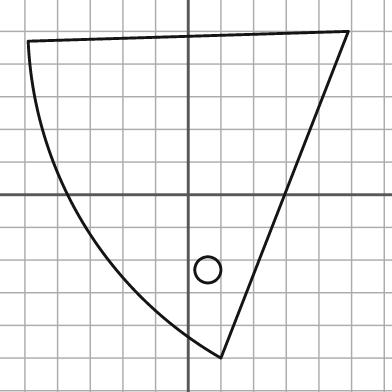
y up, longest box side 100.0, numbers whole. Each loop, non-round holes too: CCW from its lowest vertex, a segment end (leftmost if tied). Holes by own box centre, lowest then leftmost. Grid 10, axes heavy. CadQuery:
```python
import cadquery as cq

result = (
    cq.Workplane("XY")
    .moveTo(10.0, -50.0)
    .lineTo(49.0, 50.0)
    .lineTo(-49.0, 47.0)
    .threePointArc((-32.0, -9.0), (10.0, -50.0))
    .close()
    .moveTo(6.0, -23.0)
    .circle(4.0)
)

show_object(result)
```